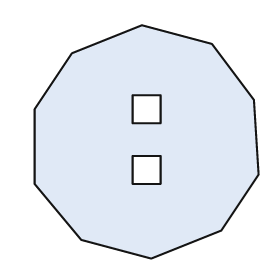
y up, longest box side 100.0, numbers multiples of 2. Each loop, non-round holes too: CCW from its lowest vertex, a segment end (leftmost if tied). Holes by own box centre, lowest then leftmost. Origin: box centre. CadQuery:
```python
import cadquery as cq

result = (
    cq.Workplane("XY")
    .moveTo(2.0, -50.0)
    .lineTo(32.0, -38.0)
    .lineTo(48.0, -14.0)
    .lineTo(46.0, 18.0)
    .lineTo(28.0, 42.0)
    .lineTo(-2.0, 50.0)
    .lineTo(-32.0, 38.0)
    .lineTo(-48.0, 14.0)
    .lineTo(-48.0, -18.0)
    .lineTo(-28.0, -42.0)
    .close()
    .moveTo(-6.0, -18.0)
    .lineTo(6.0, -18.0)
    .lineTo(6.0, -6.0)
    .lineTo(-6.0, -6.0)
    .close()
    .moveTo(-6.0, 8.0)
    .lineTo(6.0, 8.0)
    .lineTo(6.0, 20.0)
    .lineTo(-6.0, 20.0)
    .close()
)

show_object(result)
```